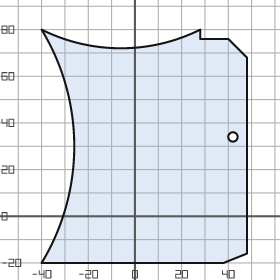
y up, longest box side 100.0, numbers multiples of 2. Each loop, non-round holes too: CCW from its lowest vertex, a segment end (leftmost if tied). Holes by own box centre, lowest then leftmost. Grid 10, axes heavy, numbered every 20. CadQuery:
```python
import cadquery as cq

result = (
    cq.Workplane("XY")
    .moveTo(-40.0, -20.0)
    .lineTo(38.0, -20.0)
    .lineTo(48.0, -16.0)
    .lineTo(48.0, 68.0)
    .lineTo(40.0, 76.0)
    .lineTo(28.0, 76.0)
    .lineTo(28.0, 80.0)
    .threePointArc((-6.0, 72.0), (-40.0, 80.0))
    .threePointArc((-26.0, 30.0), (-40.0, -20.0))
    .close()
    .moveTo(42.0, 34.0)
    .circle(2.0)
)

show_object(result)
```